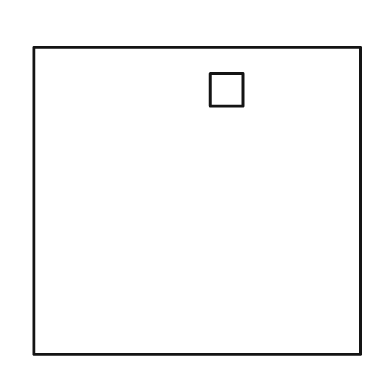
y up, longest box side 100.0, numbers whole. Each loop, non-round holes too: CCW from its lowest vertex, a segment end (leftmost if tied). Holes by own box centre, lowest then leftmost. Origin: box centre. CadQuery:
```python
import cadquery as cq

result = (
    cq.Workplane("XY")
    .moveTo(-50.0, -47.0)
    .lineTo(50.0, -47.0)
    .lineTo(50.0, 47.0)
    .lineTo(-50.0, 47.0)
    .close()
    .moveTo(4.0, 29.0)
    .lineTo(14.0, 29.0)
    .lineTo(14.0, 39.0)
    .lineTo(4.0, 39.0)
    .close()
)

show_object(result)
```